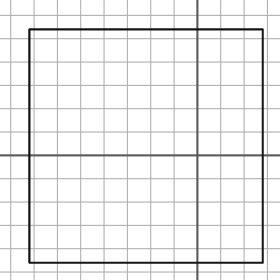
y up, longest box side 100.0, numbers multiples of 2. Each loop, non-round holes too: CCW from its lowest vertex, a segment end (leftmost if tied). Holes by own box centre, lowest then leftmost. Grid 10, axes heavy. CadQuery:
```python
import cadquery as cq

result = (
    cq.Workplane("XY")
    .moveTo(-72.0, -46.0)
    .lineTo(28.0, -46.0)
    .lineTo(28.0, 54.0)
    .lineTo(-72.0, 54.0)
    .close()
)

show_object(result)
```